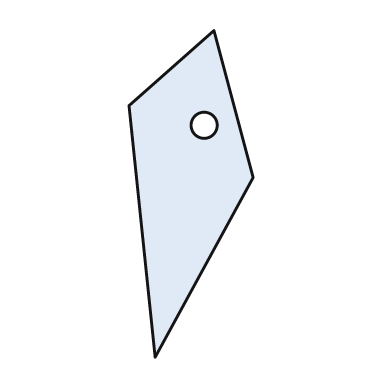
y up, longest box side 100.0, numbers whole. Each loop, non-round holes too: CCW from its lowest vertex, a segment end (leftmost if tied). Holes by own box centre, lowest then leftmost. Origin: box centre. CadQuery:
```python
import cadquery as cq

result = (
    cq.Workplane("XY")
    .moveTo(-11.0, -50.0)
    .lineTo(19.0, 5.0)
    .lineTo(7.0, 50.0)
    .lineTo(-19.0, 27.0)
    .close()
    .moveTo(4.0, 21.0)
    .circle(4.0)
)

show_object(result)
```